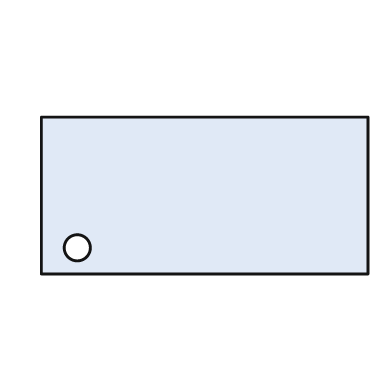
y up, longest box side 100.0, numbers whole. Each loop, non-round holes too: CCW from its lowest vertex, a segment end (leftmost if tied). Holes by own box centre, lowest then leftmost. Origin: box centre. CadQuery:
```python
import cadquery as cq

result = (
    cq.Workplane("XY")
    .moveTo(-50.0, -24.0)
    .lineTo(50.0, -24.0)
    .lineTo(50.0, 24.0)
    .lineTo(-50.0, 24.0)
    .close()
    .moveTo(-39.0, -16.0)
    .circle(4.0)
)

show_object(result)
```